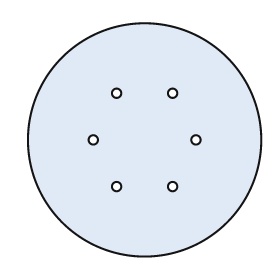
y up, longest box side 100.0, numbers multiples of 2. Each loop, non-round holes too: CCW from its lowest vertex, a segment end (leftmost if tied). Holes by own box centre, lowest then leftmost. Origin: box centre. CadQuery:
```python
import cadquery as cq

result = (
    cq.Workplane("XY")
    .moveTo(0.0, 0.0)
    .circle(50.0)
    .moveTo(-12.0, -20.0)
    .circle(2.0)
    .moveTo(12.0, -20.0)
    .circle(2.0)
    .moveTo(-22.0, 0.0)
    .circle(2.0)
    .moveTo(22.0, 0.0)
    .circle(2.0)
    .moveTo(-12.0, 20.0)
    .circle(2.0)
    .moveTo(12.0, 20.0)
    .circle(2.0)
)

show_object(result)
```